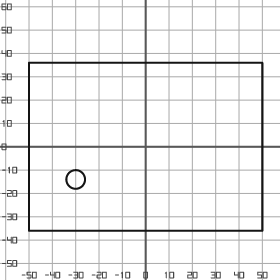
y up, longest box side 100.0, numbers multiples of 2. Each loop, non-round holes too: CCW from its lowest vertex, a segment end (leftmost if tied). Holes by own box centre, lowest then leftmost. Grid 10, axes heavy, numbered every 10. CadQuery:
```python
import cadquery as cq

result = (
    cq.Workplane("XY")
    .moveTo(-50.0, -36.0)
    .lineTo(50.0, -36.0)
    .lineTo(50.0, 36.0)
    .lineTo(-50.0, 36.0)
    .close()
    .moveTo(-30.0, -14.0)
    .circle(4.0)
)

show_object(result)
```